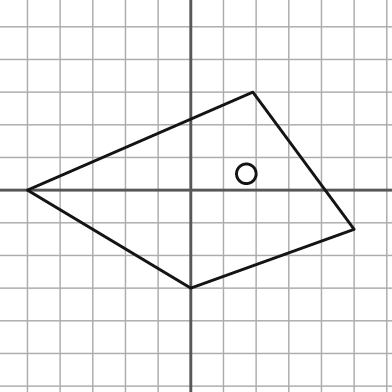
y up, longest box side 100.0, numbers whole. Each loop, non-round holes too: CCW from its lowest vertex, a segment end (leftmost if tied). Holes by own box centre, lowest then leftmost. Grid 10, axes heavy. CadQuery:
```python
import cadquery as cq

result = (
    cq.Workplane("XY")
    .moveTo(0.0, -30.0)
    .lineTo(50.0, -12.0)
    .lineTo(19.0, 30.0)
    .lineTo(-50.0, 0.0)
    .close()
    .moveTo(17.0, 5.0)
    .circle(3.0)
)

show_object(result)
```